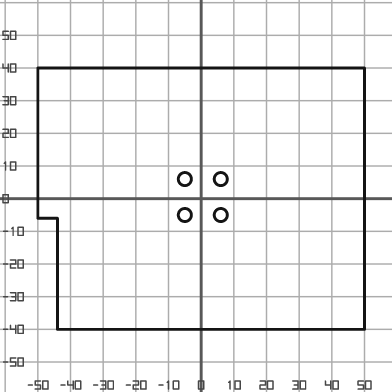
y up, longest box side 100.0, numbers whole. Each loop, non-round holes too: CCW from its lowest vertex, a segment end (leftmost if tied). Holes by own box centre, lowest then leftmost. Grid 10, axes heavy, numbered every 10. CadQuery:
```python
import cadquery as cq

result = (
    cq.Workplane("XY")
    .moveTo(-44.0, -40.0)
    .lineTo(50.0, -40.0)
    .lineTo(50.0, 40.0)
    .lineTo(-50.0, 40.0)
    .lineTo(-50.0, -6.0)
    .lineTo(-44.0, -6.0)
    .close()
    .moveTo(-5.0, -5.0)
    .circle(2.0)
    .moveTo(6.0, -5.0)
    .circle(2.0)
    .moveTo(-5.0, 6.0)
    .circle(2.0)
    .moveTo(6.0, 6.0)
    .circle(2.0)
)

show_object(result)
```